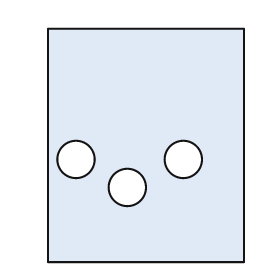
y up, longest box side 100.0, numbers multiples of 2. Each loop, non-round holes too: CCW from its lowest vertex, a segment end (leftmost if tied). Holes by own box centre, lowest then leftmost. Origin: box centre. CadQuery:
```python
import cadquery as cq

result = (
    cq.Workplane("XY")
    .moveTo(-42.0, -50.0)
    .lineTo(42.0, -50.0)
    .lineTo(42.0, 50.0)
    .lineTo(-42.0, 50.0)
    .close()
    .moveTo(-8.0, -18.0)
    .circle(8.0)
    .moveTo(-30.0, -6.0)
    .circle(8.0)
    .moveTo(16.0, -6.0)
    .circle(8.0)
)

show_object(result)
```